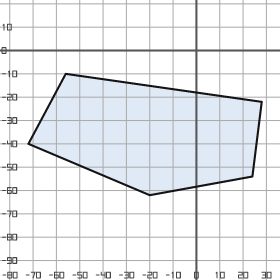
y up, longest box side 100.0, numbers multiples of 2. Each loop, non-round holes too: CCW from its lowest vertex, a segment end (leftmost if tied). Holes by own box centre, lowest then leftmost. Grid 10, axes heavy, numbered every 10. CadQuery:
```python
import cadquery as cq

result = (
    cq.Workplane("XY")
    .moveTo(-20.0, -62.0)
    .lineTo(24.0, -54.0)
    .lineTo(28.0, -22.0)
    .lineTo(-56.0, -10.0)
    .lineTo(-72.0, -40.0)
    .close()
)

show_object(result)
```